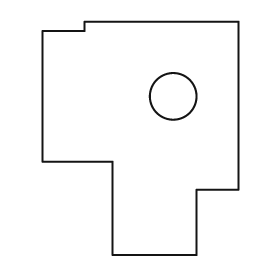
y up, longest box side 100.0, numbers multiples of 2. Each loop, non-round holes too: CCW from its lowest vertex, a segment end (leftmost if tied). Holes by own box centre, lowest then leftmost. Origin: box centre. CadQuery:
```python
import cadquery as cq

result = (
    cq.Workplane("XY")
    .moveTo(-12.0, -50.0)
    .lineTo(24.0, -50.0)
    .lineTo(24.0, -22.0)
    .lineTo(42.0, -22.0)
    .lineTo(42.0, 50.0)
    .lineTo(-24.0, 50.0)
    .lineTo(-24.0, 46.0)
    .lineTo(-42.0, 46.0)
    .lineTo(-42.0, -10.0)
    .lineTo(-12.0, -10.0)
    .close()
    .moveTo(14.0, 18.0)
    .circle(10.0)
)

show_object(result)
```